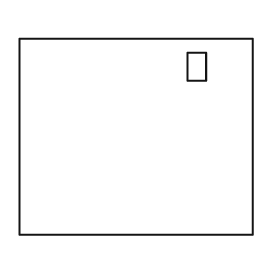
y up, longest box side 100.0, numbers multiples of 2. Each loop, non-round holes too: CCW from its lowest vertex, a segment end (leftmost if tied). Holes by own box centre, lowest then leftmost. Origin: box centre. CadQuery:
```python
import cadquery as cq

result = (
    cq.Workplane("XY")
    .moveTo(-50.0, -42.0)
    .lineTo(50.0, -42.0)
    .lineTo(50.0, 42.0)
    .lineTo(-50.0, 42.0)
    .close()
    .moveTo(22.0, 24.0)
    .lineTo(30.0, 24.0)
    .lineTo(30.0, 36.0)
    .lineTo(22.0, 36.0)
    .close()
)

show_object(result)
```